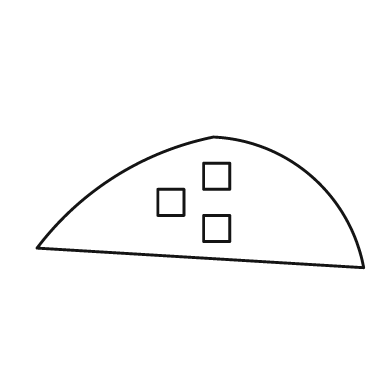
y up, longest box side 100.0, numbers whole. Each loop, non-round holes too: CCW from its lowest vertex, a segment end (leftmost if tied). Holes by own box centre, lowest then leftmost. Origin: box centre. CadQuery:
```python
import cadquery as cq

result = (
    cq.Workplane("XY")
    .moveTo(50.0, -20.0)
    .threePointArc((34.0, 8.0), (4.0, 20.0))
    .threePointArc((-26.0, 8.0), (-50.0, -14.0))
    .close()
    .moveTo(1.0, -12.0)
    .lineTo(9.0, -12.0)
    .lineTo(9.0, -4.0)
    .lineTo(1.0, -4.0)
    .close()
    .moveTo(-13.0, -4.0)
    .lineTo(-5.0, -4.0)
    .lineTo(-5.0, 4.0)
    .lineTo(-13.0, 4.0)
    .close()
    .moveTo(1.0, 4.0)
    .lineTo(9.0, 4.0)
    .lineTo(9.0, 12.0)
    .lineTo(1.0, 12.0)
    .close()
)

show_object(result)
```